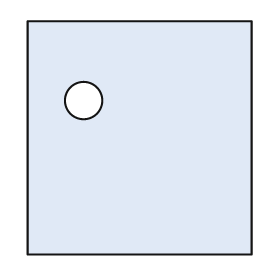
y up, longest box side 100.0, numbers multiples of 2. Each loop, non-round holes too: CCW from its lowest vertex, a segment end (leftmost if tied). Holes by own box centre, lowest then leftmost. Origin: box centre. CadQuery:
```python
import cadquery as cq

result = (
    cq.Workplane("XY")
    .moveTo(-48.0, -50.0)
    .lineTo(48.0, -50.0)
    .lineTo(48.0, 50.0)
    .lineTo(-48.0, 50.0)
    .close()
    .moveTo(-24.0, 16.0)
    .circle(8.0)
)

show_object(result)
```